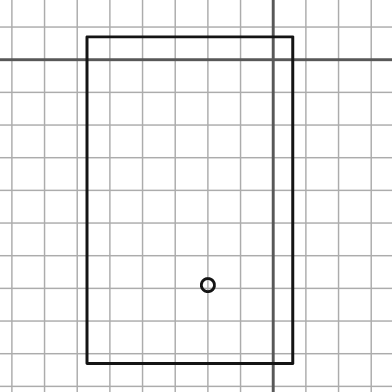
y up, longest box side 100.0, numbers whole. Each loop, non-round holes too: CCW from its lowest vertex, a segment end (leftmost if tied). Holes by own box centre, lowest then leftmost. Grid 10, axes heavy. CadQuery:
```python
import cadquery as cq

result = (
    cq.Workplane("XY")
    .moveTo(-57.0, -93.0)
    .lineTo(6.0, -93.0)
    .lineTo(6.0, 7.0)
    .lineTo(-57.0, 7.0)
    .close()
    .moveTo(-20.0, -69.0)
    .circle(2.0)
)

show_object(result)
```